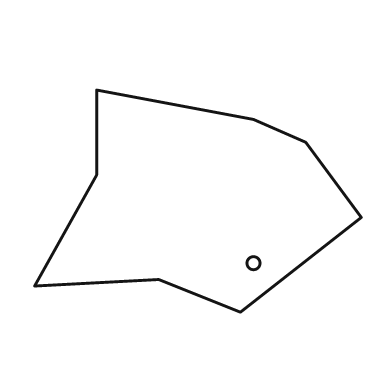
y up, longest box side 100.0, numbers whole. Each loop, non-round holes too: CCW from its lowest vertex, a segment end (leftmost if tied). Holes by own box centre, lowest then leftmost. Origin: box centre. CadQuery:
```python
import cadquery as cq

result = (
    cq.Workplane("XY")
    .moveTo(13.0, -34.0)
    .lineTo(50.0, -5.0)
    .lineTo(33.0, 18.0)
    .lineTo(17.0, 25.0)
    .lineTo(-31.0, 34.0)
    .lineTo(-31.0, 8.0)
    .lineTo(-50.0, -26.0)
    .lineTo(-12.0, -24.0)
    .close()
    .moveTo(17.0, -19.0)
    .circle(2.0)
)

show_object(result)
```